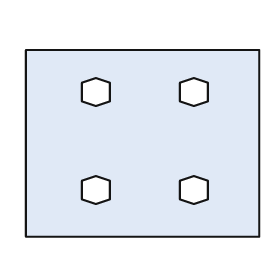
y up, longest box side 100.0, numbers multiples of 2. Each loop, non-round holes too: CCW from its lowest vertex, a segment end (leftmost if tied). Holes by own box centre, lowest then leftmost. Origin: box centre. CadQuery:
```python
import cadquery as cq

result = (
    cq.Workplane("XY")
    .moveTo(-50.0, -40.0)
    .lineTo(50.0, -40.0)
    .lineTo(50.0, 40.0)
    .lineTo(-50.0, 40.0)
    .close()
    .moveTo(-20.0, -26.0)
    .lineTo(-14.0, -24.0)
    .lineTo(-14.0, -16.0)
    .lineTo(-20.0, -14.0)
    .lineTo(-26.0, -16.0)
    .lineTo(-26.0, -24.0)
    .close()
    .moveTo(22.0, -26.0)
    .lineTo(28.0, -24.0)
    .lineTo(28.0, -16.0)
    .lineTo(22.0, -14.0)
    .lineTo(16.0, -16.0)
    .lineTo(16.0, -24.0)
    .close()
    .moveTo(-20.0, 16.0)
    .lineTo(-14.0, 18.0)
    .lineTo(-14.0, 26.0)
    .lineTo(-20.0, 28.0)
    .lineTo(-26.0, 26.0)
    .lineTo(-26.0, 18.0)
    .close()
    .moveTo(22.0, 16.0)
    .lineTo(28.0, 18.0)
    .lineTo(28.0, 26.0)
    .lineTo(22.0, 28.0)
    .lineTo(16.0, 26.0)
    .lineTo(16.0, 18.0)
    .close()
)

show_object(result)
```